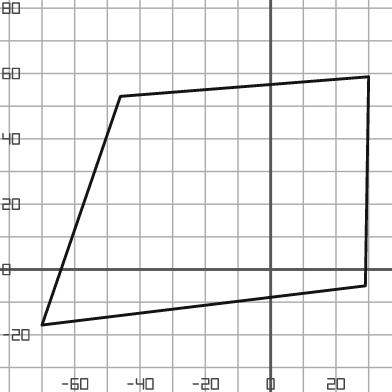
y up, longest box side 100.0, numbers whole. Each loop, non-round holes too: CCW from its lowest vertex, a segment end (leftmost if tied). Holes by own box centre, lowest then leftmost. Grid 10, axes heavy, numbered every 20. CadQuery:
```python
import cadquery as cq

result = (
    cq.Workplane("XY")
    .moveTo(-70.0, -17.0)
    .lineTo(29.0, -5.0)
    .lineTo(30.0, 59.0)
    .lineTo(-46.0, 53.0)
    .close()
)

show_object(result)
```